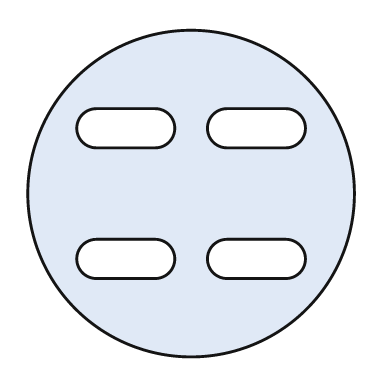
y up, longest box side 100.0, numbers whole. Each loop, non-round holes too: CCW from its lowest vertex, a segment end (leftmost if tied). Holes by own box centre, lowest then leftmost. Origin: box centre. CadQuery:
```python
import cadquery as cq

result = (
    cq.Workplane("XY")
    .moveTo(0.0, 0.0)
    .circle(50.0)
    .moveTo(-29.0, -26.0)
    .lineTo(-11.0, -26.0)
    .threePointArc((-5.0, -20.0), (-11.0, -14.0))
    .lineTo(-29.0, -14.0)
    .threePointArc((-35.0, -20.0), (-29.0, -26.0))
    .close()
    .moveTo(11.0, -26.0)
    .lineTo(29.0, -26.0)
    .threePointArc((35.0, -20.0), (29.0, -14.0))
    .lineTo(11.0, -14.0)
    .threePointArc((5.0, -20.0), (11.0, -26.0))
    .close()
    .moveTo(-29.0, 14.0)
    .lineTo(-11.0, 14.0)
    .threePointArc((-5.0, 20.0), (-11.0, 26.0))
    .lineTo(-29.0, 26.0)
    .threePointArc((-35.0, 20.0), (-29.0, 14.0))
    .close()
    .moveTo(11.0, 14.0)
    .lineTo(29.0, 14.0)
    .threePointArc((35.0, 20.0), (29.0, 26.0))
    .lineTo(11.0, 26.0)
    .threePointArc((5.0, 20.0), (11.0, 14.0))
    .close()
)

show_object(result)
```